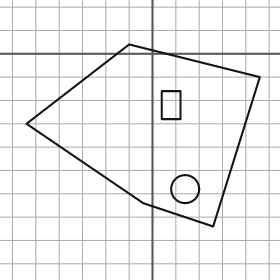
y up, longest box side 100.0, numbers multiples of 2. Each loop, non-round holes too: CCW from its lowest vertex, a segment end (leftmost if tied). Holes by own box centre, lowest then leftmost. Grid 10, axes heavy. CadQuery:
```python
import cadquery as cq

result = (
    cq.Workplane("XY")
    .moveTo(26.0, -74.0)
    .lineTo(46.0, -10.0)
    .lineTo(-10.0, 4.0)
    .lineTo(-54.0, -30.0)
    .lineTo(-4.0, -64.0)
    .close()
    .moveTo(14.0, -58.0)
    .circle(6.0)
    .moveTo(4.0, -28.0)
    .lineTo(12.0, -28.0)
    .lineTo(12.0, -16.0)
    .lineTo(4.0, -16.0)
    .close()
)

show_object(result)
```